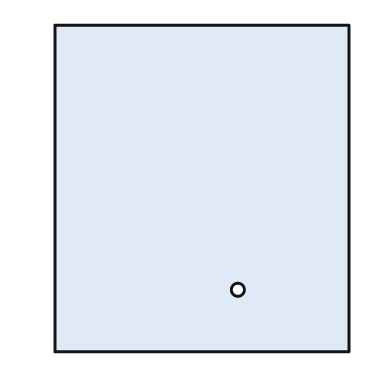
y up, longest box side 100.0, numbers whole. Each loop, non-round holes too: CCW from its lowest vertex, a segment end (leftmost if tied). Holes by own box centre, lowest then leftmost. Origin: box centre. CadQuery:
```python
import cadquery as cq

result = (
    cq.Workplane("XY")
    .moveTo(-45.0, -50.0)
    .lineTo(45.0, -50.0)
    .lineTo(45.0, 50.0)
    .lineTo(-45.0, 50.0)
    .close()
    .moveTo(11.0, -31.0)
    .circle(2.0)
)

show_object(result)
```